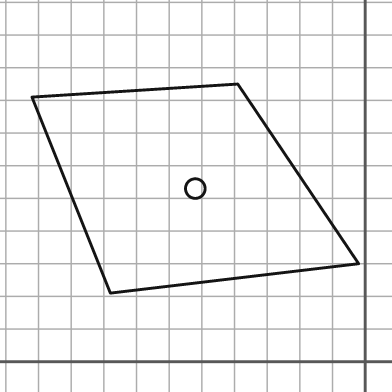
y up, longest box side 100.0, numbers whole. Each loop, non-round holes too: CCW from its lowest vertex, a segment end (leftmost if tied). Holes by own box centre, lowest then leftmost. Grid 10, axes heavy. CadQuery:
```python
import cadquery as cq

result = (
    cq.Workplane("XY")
    .moveTo(-78.0, 21.0)
    .lineTo(-2.0, 30.0)
    .lineTo(-39.0, 85.0)
    .lineTo(-102.0, 81.0)
    .close()
    .moveTo(-52.0, 53.0)
    .circle(3.0)
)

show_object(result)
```